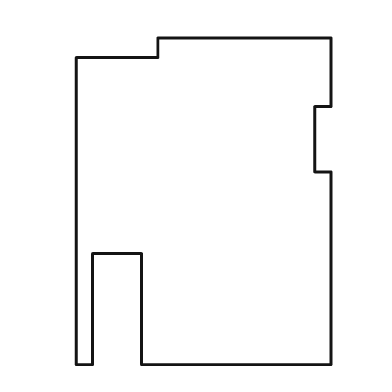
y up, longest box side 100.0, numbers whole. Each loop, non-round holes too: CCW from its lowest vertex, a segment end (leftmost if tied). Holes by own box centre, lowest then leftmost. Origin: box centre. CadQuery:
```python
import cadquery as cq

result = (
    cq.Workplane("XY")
    .moveTo(-39.0, -50.0)
    .lineTo(-34.0, -50.0)
    .lineTo(-34.0, -16.0)
    .lineTo(-19.0, -16.0)
    .lineTo(-19.0, -50.0)
    .lineTo(39.0, -50.0)
    .lineTo(39.0, 9.0)
    .lineTo(34.0, 9.0)
    .lineTo(34.0, 29.0)
    .lineTo(39.0, 29.0)
    .lineTo(39.0, 50.0)
    .lineTo(-14.0, 50.0)
    .lineTo(-14.0, 44.0)
    .lineTo(-39.0, 44.0)
    .close()
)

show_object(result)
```